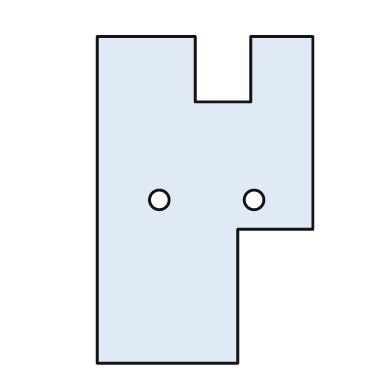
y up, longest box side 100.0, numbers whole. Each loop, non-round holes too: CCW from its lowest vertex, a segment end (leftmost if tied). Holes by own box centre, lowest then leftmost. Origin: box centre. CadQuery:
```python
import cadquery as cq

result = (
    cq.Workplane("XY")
    .moveTo(-33.0, -50.0)
    .lineTo(10.0, -50.0)
    .lineTo(10.0, -9.0)
    .lineTo(33.0, -9.0)
    .lineTo(33.0, 50.0)
    .lineTo(14.0, 50.0)
    .lineTo(14.0, 30.0)
    .lineTo(-3.0, 30.0)
    .lineTo(-3.0, 50.0)
    .lineTo(-33.0, 50.0)
    .close()
    .moveTo(-14.0, 0.0)
    .circle(3.0)
    .moveTo(15.0, 0.0)
    .circle(3.0)
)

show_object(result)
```